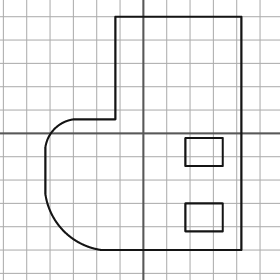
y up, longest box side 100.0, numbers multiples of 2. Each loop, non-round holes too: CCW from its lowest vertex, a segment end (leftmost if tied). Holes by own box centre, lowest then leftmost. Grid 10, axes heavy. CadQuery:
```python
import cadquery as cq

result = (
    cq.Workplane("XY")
    .moveTo(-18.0, -50.0)
    .lineTo(42.0, -50.0)
    .lineTo(42.0, 50.0)
    .lineTo(-12.0, 50.0)
    .lineTo(-12.0, 6.0)
    .lineTo(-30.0, 6.0)
    .threePointArc((-38.0, 2.0), (-42.0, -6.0))
    .lineTo(-42.0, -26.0)
    .threePointArc((-34.0, -42.0), (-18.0, -50.0))
    .close()
    .moveTo(18.0, -42.0)
    .lineTo(34.0, -42.0)
    .lineTo(34.0, -30.0)
    .lineTo(18.0, -30.0)
    .close()
    .moveTo(18.0, -14.0)
    .lineTo(34.0, -14.0)
    .lineTo(34.0, -2.0)
    .lineTo(18.0, -2.0)
    .close()
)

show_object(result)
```